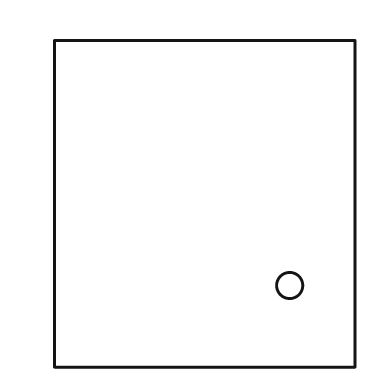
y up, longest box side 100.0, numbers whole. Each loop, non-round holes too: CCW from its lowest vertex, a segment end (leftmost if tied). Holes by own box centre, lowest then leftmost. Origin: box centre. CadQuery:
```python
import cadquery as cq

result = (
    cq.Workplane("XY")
    .moveTo(-46.0, -50.0)
    .lineTo(46.0, -50.0)
    .lineTo(46.0, 50.0)
    .lineTo(-46.0, 50.0)
    .close()
    .moveTo(26.0, -25.0)
    .circle(4.0)
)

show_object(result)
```